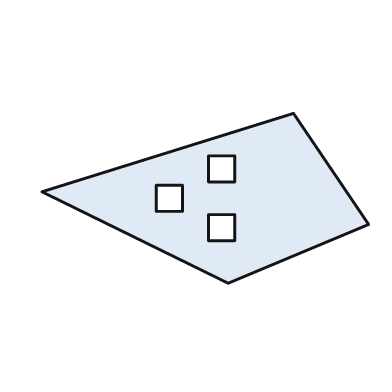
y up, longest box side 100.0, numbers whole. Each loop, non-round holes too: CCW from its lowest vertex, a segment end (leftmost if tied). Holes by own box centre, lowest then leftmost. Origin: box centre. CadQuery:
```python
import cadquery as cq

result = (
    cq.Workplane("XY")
    .moveTo(7.0, -26.0)
    .lineTo(50.0, -8.0)
    .lineTo(27.0, 26.0)
    .lineTo(-50.0, 2.0)
    .close()
    .moveTo(1.0, -13.0)
    .lineTo(9.0, -13.0)
    .lineTo(9.0, -5.0)
    .lineTo(1.0, -5.0)
    .close()
    .moveTo(-15.0, -4.0)
    .lineTo(-7.0, -4.0)
    .lineTo(-7.0, 4.0)
    .lineTo(-15.0, 4.0)
    .close()
    .moveTo(1.0, 5.0)
    .lineTo(9.0, 5.0)
    .lineTo(9.0, 13.0)
    .lineTo(1.0, 13.0)
    .close()
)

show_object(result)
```